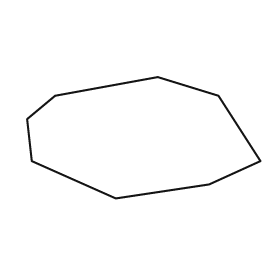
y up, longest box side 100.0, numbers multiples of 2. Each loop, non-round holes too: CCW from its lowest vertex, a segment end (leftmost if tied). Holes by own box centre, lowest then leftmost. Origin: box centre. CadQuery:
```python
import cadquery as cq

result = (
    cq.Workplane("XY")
    .moveTo(-12.0, -26.0)
    .lineTo(28.0, -20.0)
    .lineTo(50.0, -10.0)
    .lineTo(32.0, 18.0)
    .lineTo(6.0, 26.0)
    .lineTo(-38.0, 18.0)
    .lineTo(-50.0, 8.0)
    .lineTo(-48.0, -10.0)
    .close()
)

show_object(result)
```